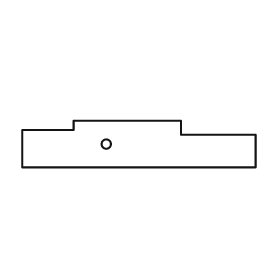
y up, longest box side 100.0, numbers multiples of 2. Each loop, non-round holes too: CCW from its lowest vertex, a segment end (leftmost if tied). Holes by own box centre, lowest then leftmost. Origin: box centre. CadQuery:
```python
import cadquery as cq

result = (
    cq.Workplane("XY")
    .moveTo(-50.0, -10.0)
    .lineTo(50.0, -10.0)
    .lineTo(50.0, 4.0)
    .lineTo(18.0, 4.0)
    .lineTo(18.0, 10.0)
    .lineTo(-28.0, 10.0)
    .lineTo(-28.0, 6.0)
    .lineTo(-50.0, 6.0)
    .close()
    .moveTo(-14.0, 0.0)
    .circle(2.0)
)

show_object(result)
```